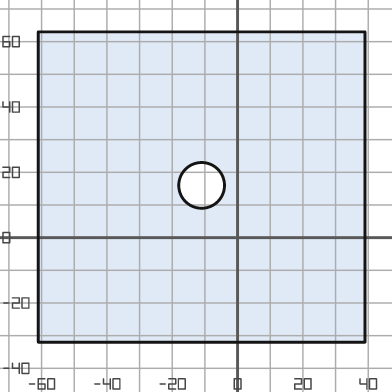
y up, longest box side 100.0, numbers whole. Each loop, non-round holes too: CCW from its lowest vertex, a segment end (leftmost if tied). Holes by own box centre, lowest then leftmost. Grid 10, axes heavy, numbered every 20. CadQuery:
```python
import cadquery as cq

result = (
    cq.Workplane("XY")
    .moveTo(-61.0, -32.0)
    .lineTo(39.0, -32.0)
    .lineTo(39.0, 63.0)
    .lineTo(-61.0, 63.0)
    .close()
    .moveTo(-11.0, 16.0)
    .circle(7.0)
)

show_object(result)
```